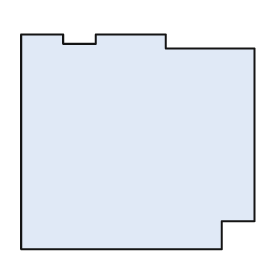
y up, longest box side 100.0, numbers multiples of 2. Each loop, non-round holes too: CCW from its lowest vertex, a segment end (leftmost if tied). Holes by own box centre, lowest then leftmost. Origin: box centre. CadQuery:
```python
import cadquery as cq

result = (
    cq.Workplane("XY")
    .moveTo(-50.0, -46.0)
    .lineTo(36.0, -46.0)
    .lineTo(36.0, -34.0)
    .lineTo(50.0, -34.0)
    .lineTo(50.0, 40.0)
    .lineTo(12.0, 40.0)
    .lineTo(12.0, 46.0)
    .lineTo(-18.0, 46.0)
    .lineTo(-18.0, 42.0)
    .lineTo(-32.0, 42.0)
    .lineTo(-32.0, 46.0)
    .lineTo(-50.0, 46.0)
    .close()
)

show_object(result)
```